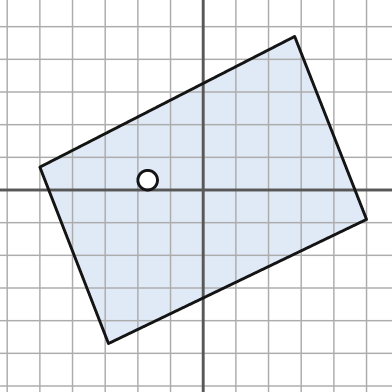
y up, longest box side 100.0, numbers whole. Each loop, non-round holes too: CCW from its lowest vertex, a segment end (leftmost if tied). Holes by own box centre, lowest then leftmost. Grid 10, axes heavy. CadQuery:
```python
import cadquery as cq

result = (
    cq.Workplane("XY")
    .moveTo(-29.0, -47.0)
    .lineTo(50.0, -9.0)
    .lineTo(28.0, 47.0)
    .lineTo(-50.0, 7.0)
    .close()
    .moveTo(-17.0, 3.0)
    .circle(3.0)
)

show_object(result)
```